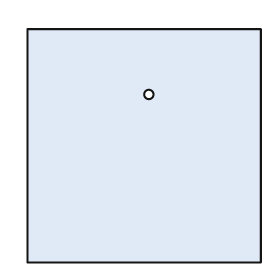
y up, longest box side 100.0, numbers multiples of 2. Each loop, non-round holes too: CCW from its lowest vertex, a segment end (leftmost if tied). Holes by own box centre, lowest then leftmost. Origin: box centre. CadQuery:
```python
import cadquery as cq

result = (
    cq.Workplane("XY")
    .moveTo(-50.0, -50.0)
    .lineTo(50.0, -50.0)
    .lineTo(50.0, 50.0)
    .lineTo(-50.0, 50.0)
    .close()
    .moveTo(2.0, 22.0)
    .circle(2.0)
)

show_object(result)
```